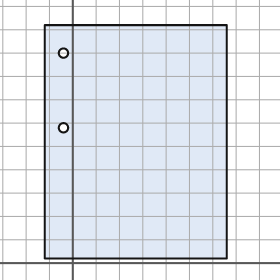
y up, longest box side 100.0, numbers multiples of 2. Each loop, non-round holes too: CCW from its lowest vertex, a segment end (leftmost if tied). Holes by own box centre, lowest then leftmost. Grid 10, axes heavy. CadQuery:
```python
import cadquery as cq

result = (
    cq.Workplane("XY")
    .moveTo(-12.0, 2.0)
    .lineTo(66.0, 2.0)
    .lineTo(66.0, 102.0)
    .lineTo(-12.0, 102.0)
    .close()
    .moveTo(-4.0, 58.0)
    .circle(2.0)
    .moveTo(-4.0, 90.0)
    .circle(2.0)
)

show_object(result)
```